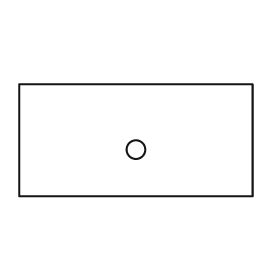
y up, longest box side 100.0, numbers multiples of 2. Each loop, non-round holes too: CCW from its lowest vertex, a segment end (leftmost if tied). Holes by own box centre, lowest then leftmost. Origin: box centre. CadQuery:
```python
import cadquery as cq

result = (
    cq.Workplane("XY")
    .moveTo(-50.0, -24.0)
    .lineTo(50.0, -24.0)
    .lineTo(50.0, 24.0)
    .lineTo(-50.0, 24.0)
    .close()
    .moveTo(0.0, -4.0)
    .circle(4.0)
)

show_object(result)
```